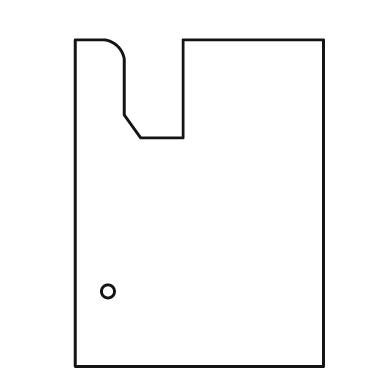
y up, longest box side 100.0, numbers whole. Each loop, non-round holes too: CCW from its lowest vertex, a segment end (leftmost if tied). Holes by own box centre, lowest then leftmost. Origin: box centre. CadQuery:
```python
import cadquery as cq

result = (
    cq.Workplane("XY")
    .moveTo(-38.0, -50.0)
    .lineTo(38.0, -50.0)
    .lineTo(38.0, 50.0)
    .lineTo(-5.0, 50.0)
    .lineTo(-5.0, 20.0)
    .lineTo(-18.0, 20.0)
    .lineTo(-23.0, 27.0)
    .lineTo(-23.0, 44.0)
    .threePointArc((-25.0, 48.0), (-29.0, 50.0))
    .lineTo(-38.0, 50.0)
    .close()
    .moveTo(-28.0, -27.0)
    .circle(2.0)
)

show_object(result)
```